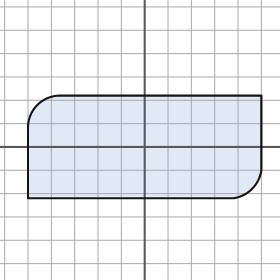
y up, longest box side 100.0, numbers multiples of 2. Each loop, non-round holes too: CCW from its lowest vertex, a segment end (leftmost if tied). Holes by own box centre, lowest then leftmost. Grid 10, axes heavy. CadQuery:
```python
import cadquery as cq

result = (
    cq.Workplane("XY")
    .moveTo(-50.0, -22.0)
    .lineTo(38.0, -22.0)
    .threePointArc((46.0, -18.0), (50.0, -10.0))
    .lineTo(50.0, 22.0)
    .lineTo(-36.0, 22.0)
    .threePointArc((-46.0, 18.0), (-50.0, 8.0))
    .close()
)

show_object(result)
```